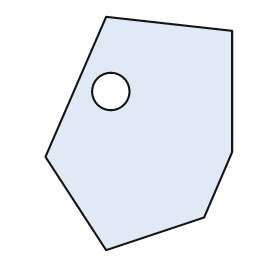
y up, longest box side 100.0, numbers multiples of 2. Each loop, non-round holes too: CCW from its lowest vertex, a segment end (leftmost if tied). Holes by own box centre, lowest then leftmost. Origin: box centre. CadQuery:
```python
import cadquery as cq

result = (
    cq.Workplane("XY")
    .moveTo(-14.0, -50.0)
    .lineTo(28.0, -36.0)
    .lineTo(40.0, -8.0)
    .lineTo(40.0, 44.0)
    .lineTo(-14.0, 50.0)
    .lineTo(-40.0, -10.0)
    .close()
    .moveTo(-12.0, 18.0)
    .circle(8.0)
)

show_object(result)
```